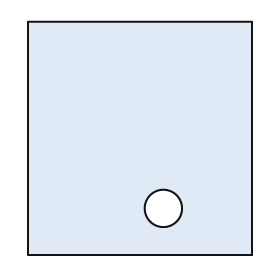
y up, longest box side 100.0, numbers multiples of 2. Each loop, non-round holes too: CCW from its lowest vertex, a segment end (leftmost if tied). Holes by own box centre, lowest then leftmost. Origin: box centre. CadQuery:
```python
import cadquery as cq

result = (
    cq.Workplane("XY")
    .moveTo(-48.0, -50.0)
    .lineTo(48.0, -50.0)
    .lineTo(48.0, 50.0)
    .lineTo(-48.0, 50.0)
    .close()
    .moveTo(10.0, -30.0)
    .circle(8.0)
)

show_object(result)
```